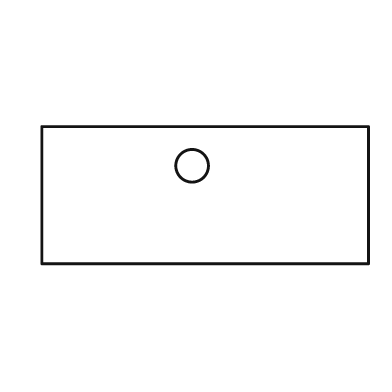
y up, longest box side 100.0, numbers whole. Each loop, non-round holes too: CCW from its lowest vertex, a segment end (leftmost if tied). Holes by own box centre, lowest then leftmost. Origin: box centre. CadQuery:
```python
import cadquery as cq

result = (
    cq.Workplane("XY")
    .moveTo(-50.0, -21.0)
    .lineTo(50.0, -21.0)
    .lineTo(50.0, 21.0)
    .lineTo(-50.0, 21.0)
    .close()
    .moveTo(-4.0, 9.0)
    .circle(5.0)
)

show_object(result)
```